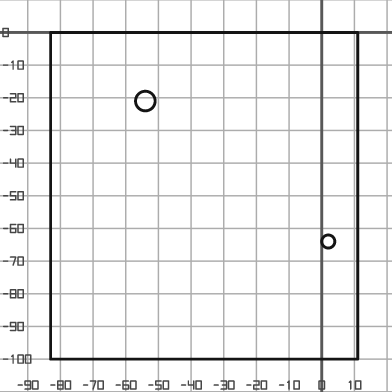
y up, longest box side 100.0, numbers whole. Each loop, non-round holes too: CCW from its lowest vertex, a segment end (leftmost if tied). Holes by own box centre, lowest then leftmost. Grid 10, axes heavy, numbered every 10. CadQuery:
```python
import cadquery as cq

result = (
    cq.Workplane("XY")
    .moveTo(-83.0, -100.0)
    .lineTo(11.0, -100.0)
    .lineTo(11.0, 0.0)
    .lineTo(-83.0, 0.0)
    .close()
    .moveTo(2.0, -64.0)
    .circle(2.0)
    .moveTo(-54.0, -21.0)
    .circle(3.0)
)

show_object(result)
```